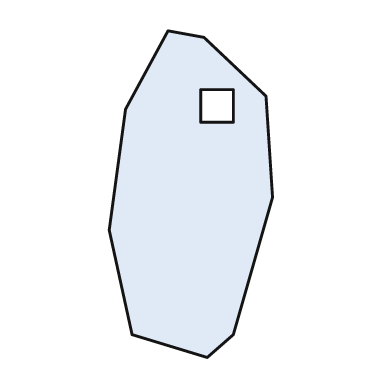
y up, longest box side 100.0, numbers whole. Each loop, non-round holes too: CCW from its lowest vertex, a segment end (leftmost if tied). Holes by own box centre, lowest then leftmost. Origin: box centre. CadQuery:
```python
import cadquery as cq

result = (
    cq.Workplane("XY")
    .moveTo(5.0, -50.0)
    .lineTo(13.0, -43.0)
    .lineTo(25.0, -1.0)
    .lineTo(23.0, 30.0)
    .lineTo(4.0, 48.0)
    .lineTo(-7.0, 50.0)
    .lineTo(-20.0, 26.0)
    .lineTo(-25.0, -11.0)
    .lineTo(-18.0, -43.0)
    .close()
    .moveTo(3.0, 22.0)
    .lineTo(13.0, 22.0)
    .lineTo(13.0, 32.0)
    .lineTo(3.0, 32.0)
    .close()
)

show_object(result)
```